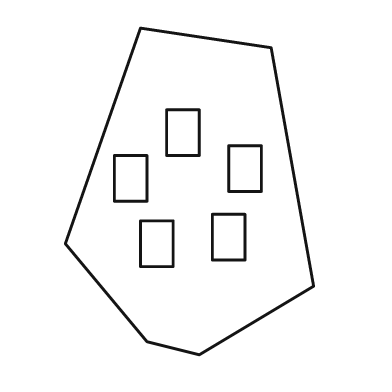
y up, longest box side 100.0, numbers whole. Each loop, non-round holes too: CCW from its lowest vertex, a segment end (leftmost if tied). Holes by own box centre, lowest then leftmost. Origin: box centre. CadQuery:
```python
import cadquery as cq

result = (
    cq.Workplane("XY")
    .moveTo(3.0, -50.0)
    .lineTo(38.0, -29.0)
    .lineTo(25.0, 44.0)
    .lineTo(-15.0, 50.0)
    .lineTo(-38.0, -16.0)
    .lineTo(-13.0, -46.0)
    .close()
    .moveTo(-15.0, -23.0)
    .lineTo(-5.0, -23.0)
    .lineTo(-5.0, -9.0)
    .lineTo(-15.0, -9.0)
    .close()
    .moveTo(7.0, -21.0)
    .lineTo(17.0, -21.0)
    .lineTo(17.0, -7.0)
    .lineTo(7.0, -7.0)
    .close()
    .moveTo(-23.0, -3.0)
    .lineTo(-13.0, -3.0)
    .lineTo(-13.0, 11.0)
    .lineTo(-23.0, 11.0)
    .close()
    .moveTo(12.0, 0.0)
    .lineTo(22.0, 0.0)
    .lineTo(22.0, 14.0)
    .lineTo(12.0, 14.0)
    .close()
    .moveTo(-7.0, 11.0)
    .lineTo(3.0, 11.0)
    .lineTo(3.0, 25.0)
    .lineTo(-7.0, 25.0)
    .close()
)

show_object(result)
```